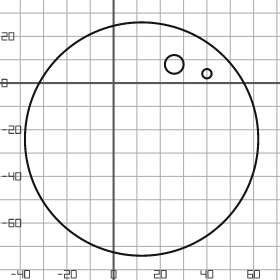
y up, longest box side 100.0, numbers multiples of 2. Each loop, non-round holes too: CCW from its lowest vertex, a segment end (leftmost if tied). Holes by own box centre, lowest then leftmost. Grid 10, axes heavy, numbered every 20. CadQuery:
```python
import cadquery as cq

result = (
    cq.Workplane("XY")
    .moveTo(12.0, -24.0)
    .circle(50.0)
    .moveTo(40.0, 4.0)
    .circle(2.0)
    .moveTo(26.0, 8.0)
    .circle(4.0)
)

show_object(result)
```